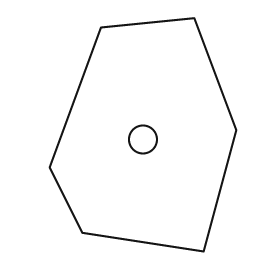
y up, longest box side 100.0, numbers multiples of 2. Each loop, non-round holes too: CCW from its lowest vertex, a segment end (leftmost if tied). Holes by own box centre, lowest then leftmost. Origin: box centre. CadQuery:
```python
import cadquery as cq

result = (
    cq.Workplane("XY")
    .moveTo(26.0, -50.0)
    .lineTo(40.0, 2.0)
    .lineTo(22.0, 50.0)
    .lineTo(-18.0, 46.0)
    .lineTo(-40.0, -14.0)
    .lineTo(-26.0, -42.0)
    .close()
    .moveTo(0.0, -2.0)
    .circle(6.0)
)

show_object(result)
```